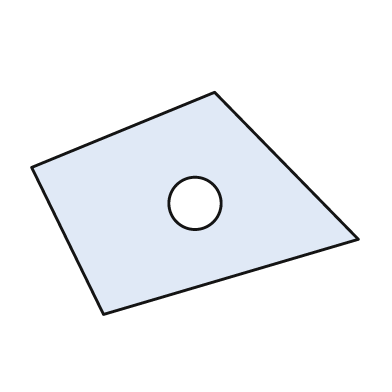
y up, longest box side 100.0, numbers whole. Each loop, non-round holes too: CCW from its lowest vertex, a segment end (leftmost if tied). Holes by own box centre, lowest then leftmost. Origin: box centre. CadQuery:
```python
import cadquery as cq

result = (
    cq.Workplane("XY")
    .moveTo(-28.0, -34.0)
    .lineTo(50.0, -11.0)
    .lineTo(6.0, 34.0)
    .lineTo(-50.0, 11.0)
    .close()
    .moveTo(0.0, 0.0)
    .circle(8.0)
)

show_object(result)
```